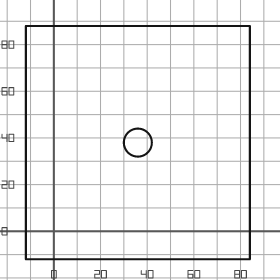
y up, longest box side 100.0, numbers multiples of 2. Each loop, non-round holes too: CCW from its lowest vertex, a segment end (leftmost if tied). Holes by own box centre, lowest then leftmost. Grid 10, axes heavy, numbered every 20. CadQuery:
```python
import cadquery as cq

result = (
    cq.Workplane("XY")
    .moveTo(-12.0, -12.0)
    .lineTo(84.0, -12.0)
    .lineTo(84.0, 88.0)
    .lineTo(-12.0, 88.0)
    .close()
    .moveTo(36.0, 38.0)
    .circle(6.0)
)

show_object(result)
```